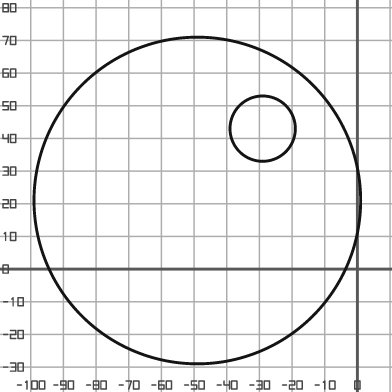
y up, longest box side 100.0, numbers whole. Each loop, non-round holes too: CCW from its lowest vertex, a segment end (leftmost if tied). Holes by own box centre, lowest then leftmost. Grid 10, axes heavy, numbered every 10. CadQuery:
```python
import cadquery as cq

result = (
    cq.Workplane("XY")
    .moveTo(-49.0, 21.0)
    .circle(50.0)
    .moveTo(-29.0, 43.0)
    .circle(10.0)
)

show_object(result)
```